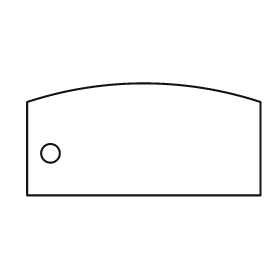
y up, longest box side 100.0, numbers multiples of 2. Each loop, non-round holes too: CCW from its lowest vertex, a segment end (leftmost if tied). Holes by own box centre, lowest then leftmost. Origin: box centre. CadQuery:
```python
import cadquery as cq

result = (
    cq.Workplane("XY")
    .moveTo(-50.0, -24.0)
    .lineTo(50.0, -24.0)
    .lineTo(50.0, 16.0)
    .threePointArc((0.0, 24.0), (-50.0, 16.0))
    .close()
    .moveTo(-40.0, -6.0)
    .circle(4.0)
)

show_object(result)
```